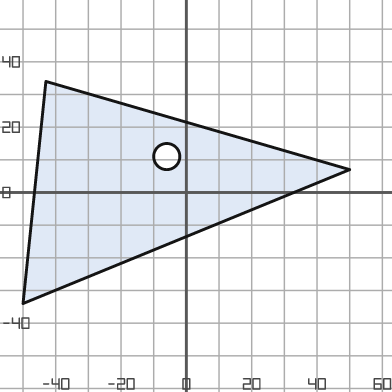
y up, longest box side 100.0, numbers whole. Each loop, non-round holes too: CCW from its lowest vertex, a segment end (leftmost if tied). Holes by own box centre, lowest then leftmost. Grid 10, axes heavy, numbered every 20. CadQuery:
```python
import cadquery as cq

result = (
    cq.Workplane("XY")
    .moveTo(-50.0, -34.0)
    .lineTo(50.0, 7.0)
    .lineTo(-43.0, 34.0)
    .close()
    .moveTo(-6.0, 11.0)
    .circle(4.0)
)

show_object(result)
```